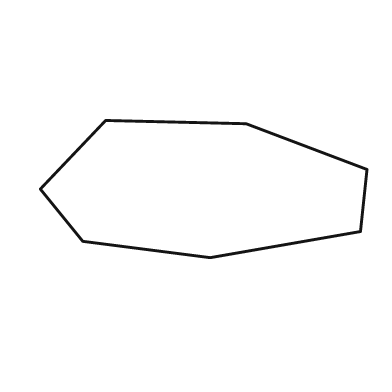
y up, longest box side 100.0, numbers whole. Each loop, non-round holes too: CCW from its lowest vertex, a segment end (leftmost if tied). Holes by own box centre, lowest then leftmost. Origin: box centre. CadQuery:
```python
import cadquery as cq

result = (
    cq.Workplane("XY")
    .moveTo(2.0, -21.0)
    .lineTo(48.0, -13.0)
    .lineTo(50.0, 6.0)
    .lineTo(13.0, 20.0)
    .lineTo(-30.0, 21.0)
    .lineTo(-50.0, 0.0)
    .lineTo(-37.0, -16.0)
    .close()
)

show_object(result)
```